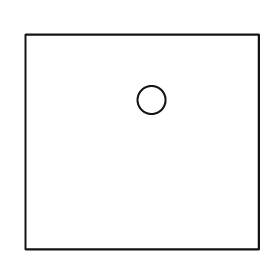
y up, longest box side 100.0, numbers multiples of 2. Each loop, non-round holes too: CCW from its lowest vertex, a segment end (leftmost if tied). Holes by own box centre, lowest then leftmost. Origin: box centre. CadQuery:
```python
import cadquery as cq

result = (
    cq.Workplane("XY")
    .moveTo(-50.0, -46.0)
    .lineTo(50.0, -46.0)
    .lineTo(50.0, 46.0)
    .lineTo(-50.0, 46.0)
    .close()
    .moveTo(4.0, 18.0)
    .circle(6.0)
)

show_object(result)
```